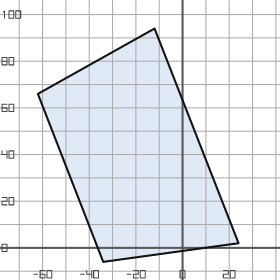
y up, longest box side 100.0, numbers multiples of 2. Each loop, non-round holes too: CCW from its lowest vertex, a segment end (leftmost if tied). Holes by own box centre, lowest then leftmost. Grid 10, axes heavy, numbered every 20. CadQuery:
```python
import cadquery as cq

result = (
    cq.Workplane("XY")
    .moveTo(-34.0, -6.0)
    .lineTo(24.0, 2.0)
    .lineTo(-12.0, 94.0)
    .lineTo(-62.0, 66.0)
    .close()
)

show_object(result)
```